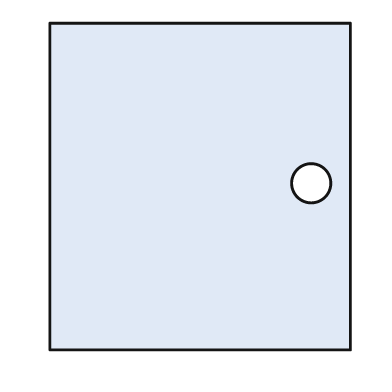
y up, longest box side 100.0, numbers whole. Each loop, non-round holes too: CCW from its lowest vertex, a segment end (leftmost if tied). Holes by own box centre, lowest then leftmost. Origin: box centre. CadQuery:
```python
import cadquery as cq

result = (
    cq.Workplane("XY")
    .moveTo(-46.0, -50.0)
    .lineTo(46.0, -50.0)
    .lineTo(46.0, 50.0)
    .lineTo(-46.0, 50.0)
    .close()
    .moveTo(34.0, 1.0)
    .circle(6.0)
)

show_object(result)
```